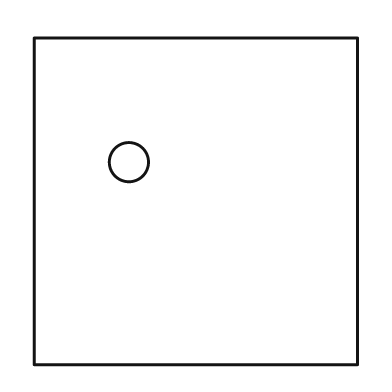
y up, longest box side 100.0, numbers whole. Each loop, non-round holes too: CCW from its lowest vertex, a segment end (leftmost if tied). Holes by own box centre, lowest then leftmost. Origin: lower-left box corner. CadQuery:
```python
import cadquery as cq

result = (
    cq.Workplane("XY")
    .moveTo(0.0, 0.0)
    .lineTo(99.0, 0.0)
    .lineTo(99.0, 100.0)
    .lineTo(0.0, 100.0)
    .close()
    .moveTo(29.0, 62.0)
    .circle(6.0)
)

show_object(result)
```